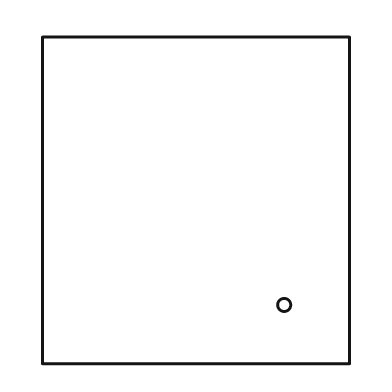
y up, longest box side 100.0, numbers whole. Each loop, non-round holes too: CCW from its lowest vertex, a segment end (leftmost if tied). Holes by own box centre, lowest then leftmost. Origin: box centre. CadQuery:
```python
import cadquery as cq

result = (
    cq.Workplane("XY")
    .moveTo(-47.0, -50.0)
    .lineTo(47.0, -50.0)
    .lineTo(47.0, 50.0)
    .lineTo(-47.0, 50.0)
    .close()
    .moveTo(27.0, -32.0)
    .circle(2.0)
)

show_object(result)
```